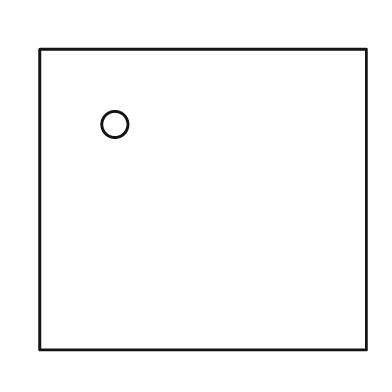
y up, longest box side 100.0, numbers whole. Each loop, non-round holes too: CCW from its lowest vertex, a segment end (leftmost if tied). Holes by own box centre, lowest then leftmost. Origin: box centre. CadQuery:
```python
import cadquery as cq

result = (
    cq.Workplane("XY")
    .moveTo(-50.0, -46.0)
    .lineTo(50.0, -46.0)
    .lineTo(50.0, 46.0)
    .lineTo(-50.0, 46.0)
    .close()
    .moveTo(-27.0, 23.0)
    .circle(4.0)
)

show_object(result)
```